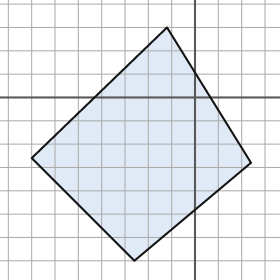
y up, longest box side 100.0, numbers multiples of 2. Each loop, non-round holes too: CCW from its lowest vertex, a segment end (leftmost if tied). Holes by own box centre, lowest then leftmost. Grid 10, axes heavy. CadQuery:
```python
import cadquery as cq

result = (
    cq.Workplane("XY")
    .moveTo(-26.0, -70.0)
    .lineTo(24.0, -28.0)
    .lineTo(-12.0, 30.0)
    .lineTo(-70.0, -26.0)
    .close()
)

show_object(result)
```